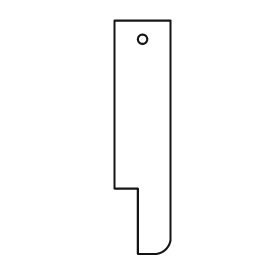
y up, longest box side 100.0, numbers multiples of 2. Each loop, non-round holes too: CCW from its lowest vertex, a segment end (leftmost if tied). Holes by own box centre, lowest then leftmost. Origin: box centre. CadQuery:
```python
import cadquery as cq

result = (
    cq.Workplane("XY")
    .moveTo(-2.0, -50.0)
    .lineTo(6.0, -50.0)
    .threePointArc((10.0, -48.0), (12.0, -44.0))
    .lineTo(12.0, 50.0)
    .lineTo(-12.0, 50.0)
    .lineTo(-12.0, -22.0)
    .lineTo(-2.0, -22.0)
    .close()
    .moveTo(0.0, 42.0)
    .circle(2.0)
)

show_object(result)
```